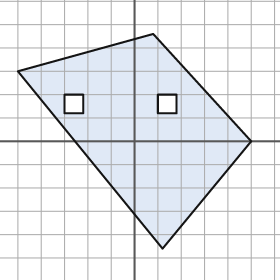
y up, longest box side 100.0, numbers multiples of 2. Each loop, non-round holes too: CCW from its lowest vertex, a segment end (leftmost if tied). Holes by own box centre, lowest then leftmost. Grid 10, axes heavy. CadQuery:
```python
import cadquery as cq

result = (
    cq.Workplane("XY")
    .moveTo(12.0, -46.0)
    .lineTo(50.0, 0.0)
    .lineTo(8.0, 46.0)
    .lineTo(-50.0, 30.0)
    .close()
    .moveTo(-30.0, 12.0)
    .lineTo(-22.0, 12.0)
    .lineTo(-22.0, 20.0)
    .lineTo(-30.0, 20.0)
    .close()
    .moveTo(10.0, 12.0)
    .lineTo(18.0, 12.0)
    .lineTo(18.0, 20.0)
    .lineTo(10.0, 20.0)
    .close()
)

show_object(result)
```